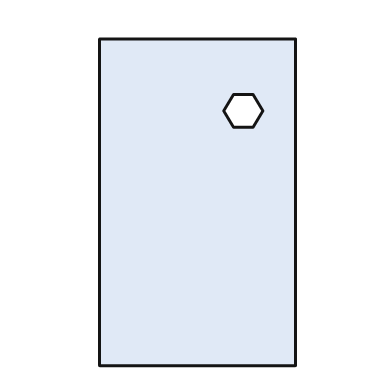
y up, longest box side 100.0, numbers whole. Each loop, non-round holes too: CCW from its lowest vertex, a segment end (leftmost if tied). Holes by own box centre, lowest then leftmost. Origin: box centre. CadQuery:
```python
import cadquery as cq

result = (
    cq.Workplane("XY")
    .moveTo(-30.0, -50.0)
    .lineTo(30.0, -50.0)
    .lineTo(30.0, 50.0)
    .lineTo(-30.0, 50.0)
    .close()
    .moveTo(11.0, 23.0)
    .lineTo(17.0, 23.0)
    .lineTo(20.0, 28.0)
    .lineTo(17.0, 33.0)
    .lineTo(11.0, 33.0)
    .lineTo(8.0, 28.0)
    .close()
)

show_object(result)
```